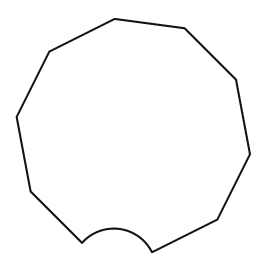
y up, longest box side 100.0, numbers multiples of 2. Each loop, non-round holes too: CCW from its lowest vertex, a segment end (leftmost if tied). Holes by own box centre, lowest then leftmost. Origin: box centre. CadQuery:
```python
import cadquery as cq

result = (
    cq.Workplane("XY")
    .moveTo(8.0, -50.0)
    .lineTo(36.0, -36.0)
    .lineTo(50.0, -8.0)
    .lineTo(44.0, 24.0)
    .lineTo(22.0, 46.0)
    .lineTo(-8.0, 50.0)
    .lineTo(-36.0, 36.0)
    .lineTo(-50.0, 8.0)
    .lineTo(-44.0, -24.0)
    .lineTo(-22.0, -46.0)
    .threePointArc((-6.0, -40.0), (8.0, -50.0))
    .close()
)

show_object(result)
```